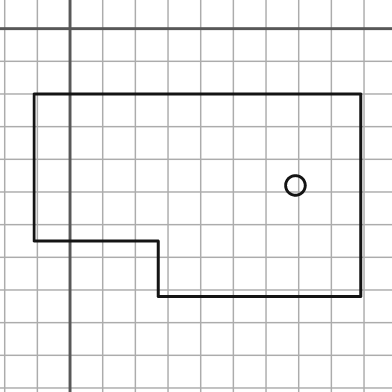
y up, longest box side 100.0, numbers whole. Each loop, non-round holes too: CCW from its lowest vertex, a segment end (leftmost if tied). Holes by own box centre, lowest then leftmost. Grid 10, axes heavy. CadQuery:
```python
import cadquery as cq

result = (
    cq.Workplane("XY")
    .moveTo(27.0, -82.0)
    .lineTo(89.0, -82.0)
    .lineTo(89.0, -20.0)
    .lineTo(-11.0, -20.0)
    .lineTo(-11.0, -65.0)
    .lineTo(27.0, -65.0)
    .close()
    .moveTo(69.0, -48.0)
    .circle(3.0)
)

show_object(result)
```